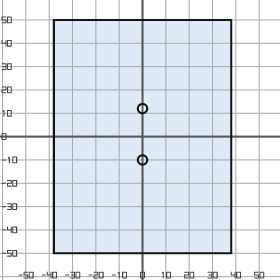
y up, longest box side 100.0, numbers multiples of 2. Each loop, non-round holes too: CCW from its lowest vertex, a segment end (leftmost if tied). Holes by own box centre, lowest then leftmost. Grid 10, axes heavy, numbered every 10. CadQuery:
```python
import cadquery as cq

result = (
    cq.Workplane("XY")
    .moveTo(-38.0, -50.0)
    .lineTo(38.0, -50.0)
    .lineTo(38.0, 50.0)
    .lineTo(-38.0, 50.0)
    .close()
    .moveTo(0.0, -10.0)
    .circle(2.0)
    .moveTo(0.0, 12.0)
    .circle(2.0)
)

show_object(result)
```